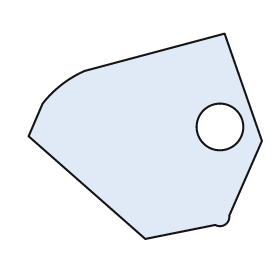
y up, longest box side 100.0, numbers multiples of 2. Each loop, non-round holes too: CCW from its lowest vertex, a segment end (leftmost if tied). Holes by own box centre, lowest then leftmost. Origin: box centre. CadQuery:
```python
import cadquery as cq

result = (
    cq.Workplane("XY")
    .moveTo(0.0, -44.0)
    .lineTo(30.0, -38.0)
    .threePointArc((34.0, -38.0), (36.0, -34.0))
    .lineTo(50.0, -2.0)
    .lineTo(34.0, 44.0)
    .lineTo(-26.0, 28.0)
    .threePointArc((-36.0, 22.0), (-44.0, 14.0))
    .lineTo(-50.0, 0.0)
    .close()
    .moveTo(32.0, 4.0)
    .circle(10.0)
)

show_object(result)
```